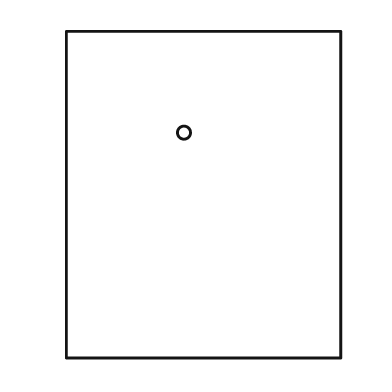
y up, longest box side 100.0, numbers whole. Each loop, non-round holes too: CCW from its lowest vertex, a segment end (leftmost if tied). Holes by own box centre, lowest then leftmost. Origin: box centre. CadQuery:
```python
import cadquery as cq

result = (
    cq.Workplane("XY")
    .moveTo(-42.0, -50.0)
    .lineTo(42.0, -50.0)
    .lineTo(42.0, 50.0)
    .lineTo(-42.0, 50.0)
    .close()
    .moveTo(-6.0, 19.0)
    .circle(2.0)
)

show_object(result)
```